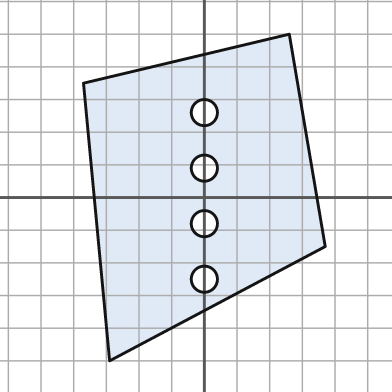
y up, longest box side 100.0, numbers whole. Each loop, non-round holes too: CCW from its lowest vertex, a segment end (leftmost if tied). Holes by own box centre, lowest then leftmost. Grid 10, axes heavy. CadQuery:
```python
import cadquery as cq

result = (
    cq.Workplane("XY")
    .moveTo(-29.0, -50.0)
    .lineTo(37.0, -15.0)
    .lineTo(26.0, 50.0)
    .lineTo(-37.0, 35.0)
    .close()
    .moveTo(0.0, -25.0)
    .circle(4.0)
    .moveTo(0.0, -8.0)
    .circle(4.0)
    .moveTo(0.0, 9.0)
    .circle(4.0)
    .moveTo(0.0, 26.0)
    .circle(4.0)
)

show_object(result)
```